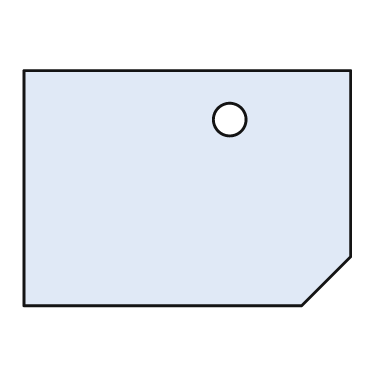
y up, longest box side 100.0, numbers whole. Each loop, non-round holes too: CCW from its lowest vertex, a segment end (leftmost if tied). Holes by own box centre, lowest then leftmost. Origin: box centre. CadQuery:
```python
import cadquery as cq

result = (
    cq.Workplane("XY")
    .moveTo(-50.0, -36.0)
    .lineTo(35.0, -36.0)
    .lineTo(50.0, -21.0)
    .lineTo(50.0, 36.0)
    .lineTo(-50.0, 36.0)
    .close()
    .moveTo(13.0, 21.0)
    .circle(5.0)
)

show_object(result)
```